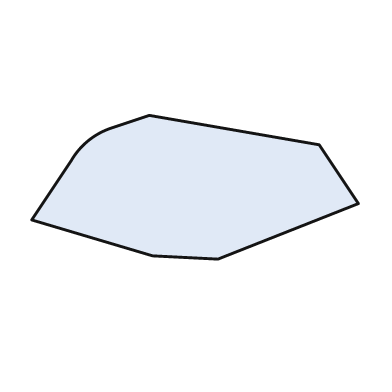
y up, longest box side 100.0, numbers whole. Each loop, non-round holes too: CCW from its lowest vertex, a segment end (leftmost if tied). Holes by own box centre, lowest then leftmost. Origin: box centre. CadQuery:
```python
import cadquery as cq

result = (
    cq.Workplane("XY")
    .moveTo(7.0, -22.0)
    .lineTo(50.0, -5.0)
    .lineTo(38.0, 13.0)
    .lineTo(-14.0, 22.0)
    .lineTo(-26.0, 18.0)
    .threePointArc((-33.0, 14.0), (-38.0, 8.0))
    .lineTo(-50.0, -10.0)
    .lineTo(-13.0, -21.0)
    .close()
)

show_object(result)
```